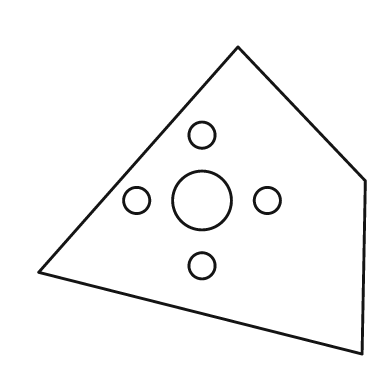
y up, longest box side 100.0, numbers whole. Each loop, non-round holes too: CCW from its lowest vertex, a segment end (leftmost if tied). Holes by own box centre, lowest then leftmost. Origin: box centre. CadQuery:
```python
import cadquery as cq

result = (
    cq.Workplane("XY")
    .moveTo(49.0, -47.0)
    .lineTo(50.0, 6.0)
    .lineTo(11.0, 47.0)
    .lineTo(-50.0, -22.0)
    .close()
    .moveTo(0.0, -20.0)
    .circle(4.0)
    .moveTo(-20.0, 0.0)
    .circle(4.0)
    .moveTo(0.0, 0.0)
    .circle(9.0)
    .moveTo(20.0, 0.0)
    .circle(4.0)
    .moveTo(0.0, 20.0)
    .circle(4.0)
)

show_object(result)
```